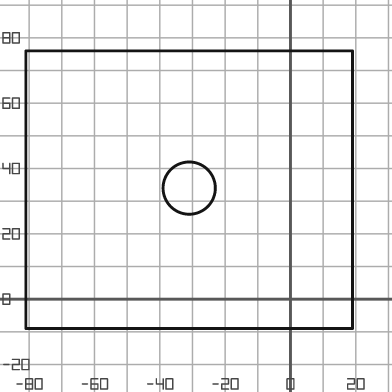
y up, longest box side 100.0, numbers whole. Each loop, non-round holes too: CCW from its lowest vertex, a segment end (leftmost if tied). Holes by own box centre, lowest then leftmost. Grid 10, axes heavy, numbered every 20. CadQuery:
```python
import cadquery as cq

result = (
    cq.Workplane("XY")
    .moveTo(-81.0, -9.0)
    .lineTo(19.0, -9.0)
    .lineTo(19.0, 76.0)
    .lineTo(-81.0, 76.0)
    .close()
    .moveTo(-31.0, 34.0)
    .circle(8.0)
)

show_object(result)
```